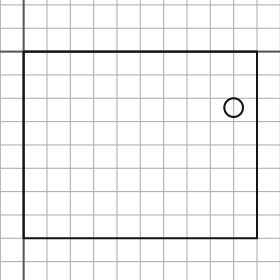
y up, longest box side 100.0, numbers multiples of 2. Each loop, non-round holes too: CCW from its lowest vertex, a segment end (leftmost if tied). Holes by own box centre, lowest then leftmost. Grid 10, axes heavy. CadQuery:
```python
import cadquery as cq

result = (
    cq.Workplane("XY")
    .moveTo(0.0, -80.0)
    .lineTo(100.0, -80.0)
    .lineTo(100.0, 0.0)
    .lineTo(0.0, 0.0)
    .close()
    .moveTo(90.0, -24.0)
    .circle(4.0)
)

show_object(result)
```